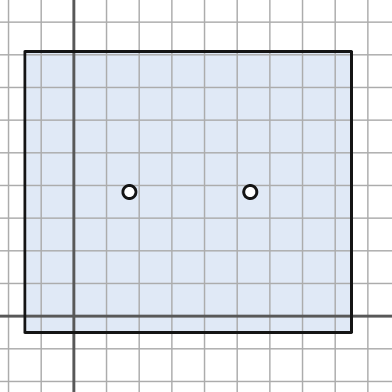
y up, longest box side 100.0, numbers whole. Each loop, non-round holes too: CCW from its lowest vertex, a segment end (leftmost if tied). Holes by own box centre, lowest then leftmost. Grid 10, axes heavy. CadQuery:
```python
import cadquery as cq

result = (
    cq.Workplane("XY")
    .moveTo(-15.0, -5.0)
    .lineTo(85.0, -5.0)
    .lineTo(85.0, 81.0)
    .lineTo(-15.0, 81.0)
    .close()
    .moveTo(17.0, 38.0)
    .circle(2.0)
    .moveTo(54.0, 38.0)
    .circle(2.0)
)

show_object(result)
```